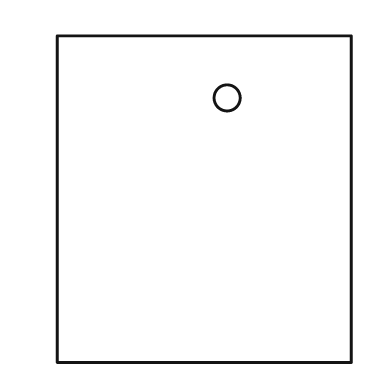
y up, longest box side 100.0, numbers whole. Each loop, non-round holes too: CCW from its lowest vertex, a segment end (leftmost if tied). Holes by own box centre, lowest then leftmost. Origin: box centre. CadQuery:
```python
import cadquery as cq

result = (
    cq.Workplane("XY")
    .moveTo(-45.0, -50.0)
    .lineTo(45.0, -50.0)
    .lineTo(45.0, 50.0)
    .lineTo(-45.0, 50.0)
    .close()
    .moveTo(7.0, 31.0)
    .circle(4.0)
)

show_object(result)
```